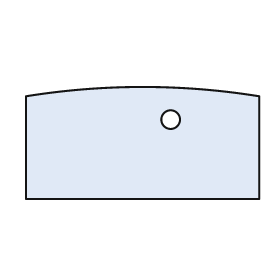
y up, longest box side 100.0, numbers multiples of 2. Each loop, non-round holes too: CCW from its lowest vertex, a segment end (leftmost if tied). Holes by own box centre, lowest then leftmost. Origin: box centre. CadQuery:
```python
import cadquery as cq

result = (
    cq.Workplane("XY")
    .moveTo(-50.0, -24.0)
    .lineTo(50.0, -24.0)
    .lineTo(50.0, 20.0)
    .threePointArc((0.0, 24.0), (-50.0, 20.0))
    .close()
    .moveTo(12.0, 10.0)
    .circle(4.0)
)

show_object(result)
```